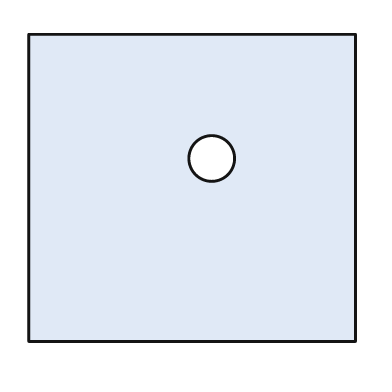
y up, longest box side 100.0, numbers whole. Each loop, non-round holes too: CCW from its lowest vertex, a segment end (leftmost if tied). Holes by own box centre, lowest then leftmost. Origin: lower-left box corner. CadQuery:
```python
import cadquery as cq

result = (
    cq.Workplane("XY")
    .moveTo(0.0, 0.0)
    .lineTo(100.0, 0.0)
    .lineTo(100.0, 94.0)
    .lineTo(0.0, 94.0)
    .close()
    .moveTo(56.0, 56.0)
    .circle(7.0)
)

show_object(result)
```